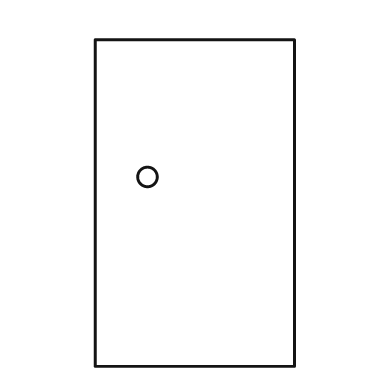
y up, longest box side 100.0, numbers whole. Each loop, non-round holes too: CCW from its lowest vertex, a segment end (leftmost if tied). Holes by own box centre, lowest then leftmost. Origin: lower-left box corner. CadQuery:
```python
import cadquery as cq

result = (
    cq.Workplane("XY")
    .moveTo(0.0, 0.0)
    .lineTo(61.0, 0.0)
    .lineTo(61.0, 100.0)
    .lineTo(0.0, 100.0)
    .close()
    .moveTo(16.0, 58.0)
    .circle(3.0)
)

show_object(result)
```